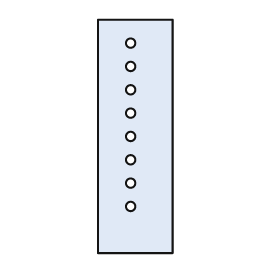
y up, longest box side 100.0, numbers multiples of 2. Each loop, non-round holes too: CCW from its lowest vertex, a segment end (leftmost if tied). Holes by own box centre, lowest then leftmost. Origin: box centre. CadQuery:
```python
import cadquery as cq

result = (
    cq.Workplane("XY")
    .moveTo(-16.0, -50.0)
    .lineTo(16.0, -50.0)
    .lineTo(16.0, 50.0)
    .lineTo(-16.0, 50.0)
    .close()
    .moveTo(-2.0, -30.0)
    .circle(2.0)
    .moveTo(-2.0, -20.0)
    .circle(2.0)
    .moveTo(-2.0, -10.0)
    .circle(2.0)
    .moveTo(-2.0, 0.0)
    .circle(2.0)
    .moveTo(-2.0, 10.0)
    .circle(2.0)
    .moveTo(-2.0, 20.0)
    .circle(2.0)
    .moveTo(-2.0, 30.0)
    .circle(2.0)
    .moveTo(-2.0, 40.0)
    .circle(2.0)
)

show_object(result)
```